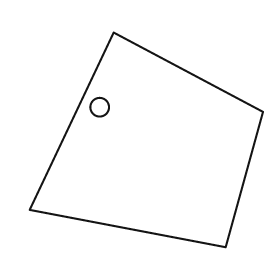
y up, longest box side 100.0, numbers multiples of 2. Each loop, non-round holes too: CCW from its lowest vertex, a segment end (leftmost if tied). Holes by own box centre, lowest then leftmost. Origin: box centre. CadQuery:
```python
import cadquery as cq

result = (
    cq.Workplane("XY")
    .moveTo(34.0, -46.0)
    .lineTo(50.0, 12.0)
    .lineTo(-14.0, 46.0)
    .lineTo(-50.0, -30.0)
    .close()
    .moveTo(-20.0, 14.0)
    .circle(4.0)
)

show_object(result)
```